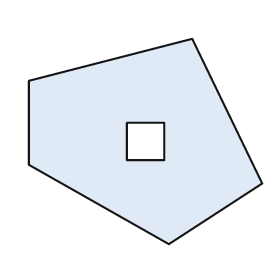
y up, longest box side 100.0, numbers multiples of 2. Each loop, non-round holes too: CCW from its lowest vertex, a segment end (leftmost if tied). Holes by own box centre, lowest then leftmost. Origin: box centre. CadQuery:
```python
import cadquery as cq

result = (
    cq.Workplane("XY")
    .moveTo(10.0, -44.0)
    .lineTo(50.0, -18.0)
    .lineTo(20.0, 44.0)
    .lineTo(-50.0, 26.0)
    .lineTo(-50.0, -10.0)
    .close()
    .moveTo(-8.0, -8.0)
    .lineTo(8.0, -8.0)
    .lineTo(8.0, 8.0)
    .lineTo(-8.0, 8.0)
    .close()
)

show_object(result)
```